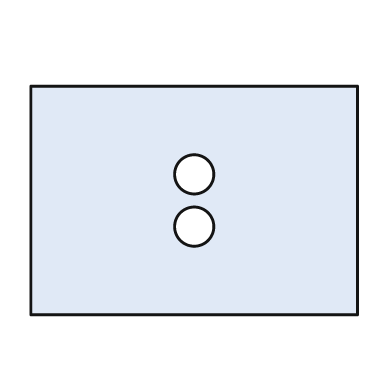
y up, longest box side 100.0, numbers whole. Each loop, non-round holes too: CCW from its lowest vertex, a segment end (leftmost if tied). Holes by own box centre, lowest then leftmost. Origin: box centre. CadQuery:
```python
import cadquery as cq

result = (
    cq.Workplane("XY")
    .moveTo(-50.0, -35.0)
    .lineTo(50.0, -35.0)
    .lineTo(50.0, 35.0)
    .lineTo(-50.0, 35.0)
    .close()
    .moveTo(0.0, -8.0)
    .circle(6.0)
    .moveTo(0.0, 8.0)
    .circle(6.0)
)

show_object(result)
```